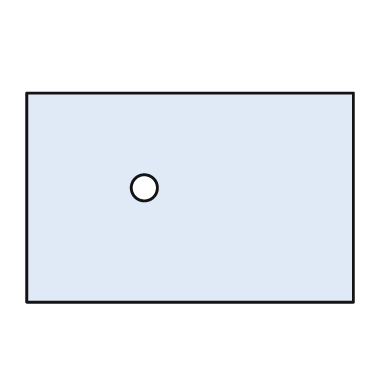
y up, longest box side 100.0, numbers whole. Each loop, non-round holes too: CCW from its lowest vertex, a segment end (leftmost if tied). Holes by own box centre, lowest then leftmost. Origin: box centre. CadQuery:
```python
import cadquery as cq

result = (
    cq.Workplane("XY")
    .moveTo(-50.0, -32.0)
    .lineTo(50.0, -32.0)
    .lineTo(50.0, 32.0)
    .lineTo(-50.0, 32.0)
    .close()
    .moveTo(-14.0, 3.0)
    .circle(4.0)
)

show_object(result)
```